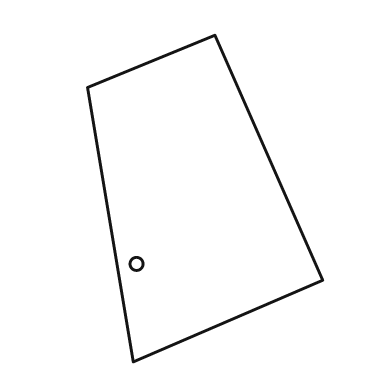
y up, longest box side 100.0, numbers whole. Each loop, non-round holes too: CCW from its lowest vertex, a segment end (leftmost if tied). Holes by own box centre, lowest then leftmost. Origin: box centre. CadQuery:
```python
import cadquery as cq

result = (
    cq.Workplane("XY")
    .moveTo(-22.0, -50.0)
    .lineTo(36.0, -25.0)
    .lineTo(3.0, 50.0)
    .lineTo(-36.0, 34.0)
    .close()
    .moveTo(-21.0, -20.0)
    .circle(2.0)
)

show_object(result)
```